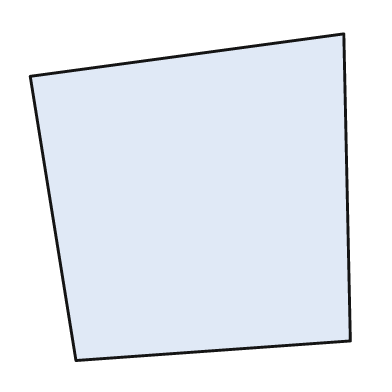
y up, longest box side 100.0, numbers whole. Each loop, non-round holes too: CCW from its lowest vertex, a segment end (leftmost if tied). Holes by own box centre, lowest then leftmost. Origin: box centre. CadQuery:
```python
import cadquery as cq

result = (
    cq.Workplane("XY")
    .moveTo(-35.0, -50.0)
    .lineTo(49.0, -44.0)
    .lineTo(47.0, 50.0)
    .lineTo(-49.0, 37.0)
    .close()
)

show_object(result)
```